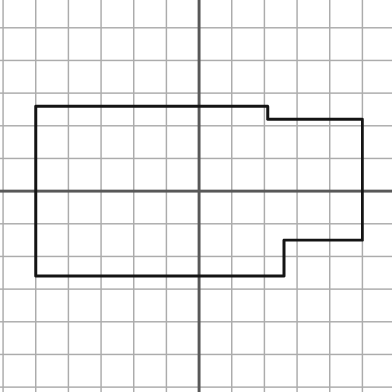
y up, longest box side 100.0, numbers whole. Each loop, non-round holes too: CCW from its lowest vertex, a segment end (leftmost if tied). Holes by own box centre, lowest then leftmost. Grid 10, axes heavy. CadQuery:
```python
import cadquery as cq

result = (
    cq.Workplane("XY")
    .moveTo(-50.0, -26.0)
    .lineTo(26.0, -26.0)
    .lineTo(26.0, -15.0)
    .lineTo(50.0, -15.0)
    .lineTo(50.0, 22.0)
    .lineTo(21.0, 22.0)
    .lineTo(21.0, 26.0)
    .lineTo(-50.0, 26.0)
    .close()
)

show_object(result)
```